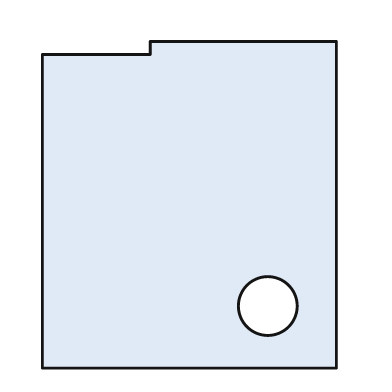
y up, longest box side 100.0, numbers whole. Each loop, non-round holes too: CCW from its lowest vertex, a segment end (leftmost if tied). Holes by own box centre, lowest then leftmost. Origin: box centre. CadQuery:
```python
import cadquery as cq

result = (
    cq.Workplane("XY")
    .moveTo(-45.0, -50.0)
    .lineTo(45.0, -50.0)
    .lineTo(45.0, 50.0)
    .lineTo(-12.0, 50.0)
    .lineTo(-12.0, 46.0)
    .lineTo(-45.0, 46.0)
    .close()
    .moveTo(24.0, -31.0)
    .circle(9.0)
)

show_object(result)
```